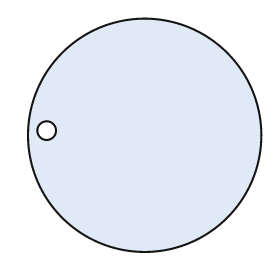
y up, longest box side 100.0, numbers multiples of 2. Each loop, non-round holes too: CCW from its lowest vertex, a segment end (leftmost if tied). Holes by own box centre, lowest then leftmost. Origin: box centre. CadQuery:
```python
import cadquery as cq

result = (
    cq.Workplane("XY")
    .moveTo(0.0, 0.0)
    .circle(50.0)
    .moveTo(-42.0, 2.0)
    .circle(4.0)
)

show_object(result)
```